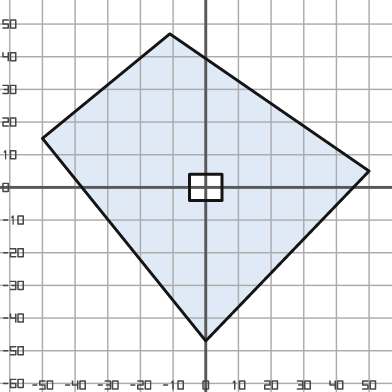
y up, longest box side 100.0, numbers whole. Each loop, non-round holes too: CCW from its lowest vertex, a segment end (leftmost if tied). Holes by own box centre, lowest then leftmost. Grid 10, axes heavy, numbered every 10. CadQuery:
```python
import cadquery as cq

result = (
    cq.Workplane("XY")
    .moveTo(0.0, -47.0)
    .lineTo(50.0, 5.0)
    .lineTo(-11.0, 47.0)
    .lineTo(-50.0, 15.0)
    .close()
    .moveTo(-5.0, -4.0)
    .lineTo(5.0, -4.0)
    .lineTo(5.0, 4.0)
    .lineTo(-5.0, 4.0)
    .close()
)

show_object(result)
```